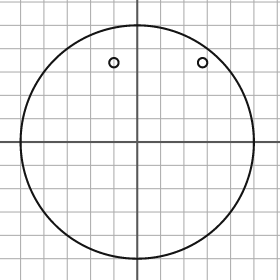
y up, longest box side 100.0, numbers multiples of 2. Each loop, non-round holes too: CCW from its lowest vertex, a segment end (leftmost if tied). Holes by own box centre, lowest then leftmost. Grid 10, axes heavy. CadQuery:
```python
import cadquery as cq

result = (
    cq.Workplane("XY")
    .moveTo(0.0, 0.0)
    .circle(50.0)
    .moveTo(-10.0, 34.0)
    .circle(2.0)
    .moveTo(28.0, 34.0)
    .circle(2.0)
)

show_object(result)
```